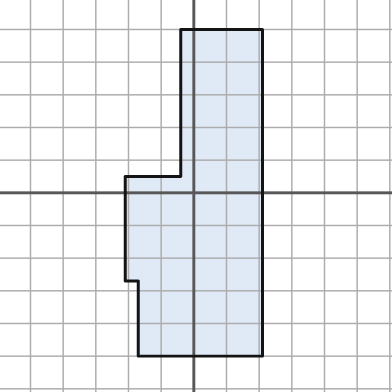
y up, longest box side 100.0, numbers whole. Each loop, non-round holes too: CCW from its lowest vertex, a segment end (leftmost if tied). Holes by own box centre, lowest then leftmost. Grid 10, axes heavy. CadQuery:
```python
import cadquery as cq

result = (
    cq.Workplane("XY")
    .moveTo(-17.0, -50.0)
    .lineTo(21.0, -50.0)
    .lineTo(21.0, 50.0)
    .lineTo(-4.0, 50.0)
    .lineTo(-4.0, 5.0)
    .lineTo(-21.0, 5.0)
    .lineTo(-21.0, -27.0)
    .lineTo(-17.0, -27.0)
    .close()
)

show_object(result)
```